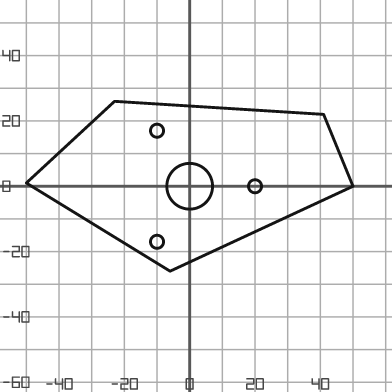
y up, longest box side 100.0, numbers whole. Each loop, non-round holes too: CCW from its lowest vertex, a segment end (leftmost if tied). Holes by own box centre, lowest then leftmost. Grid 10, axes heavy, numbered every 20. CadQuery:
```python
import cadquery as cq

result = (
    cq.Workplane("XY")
    .moveTo(-6.0, -26.0)
    .lineTo(50.0, 0.0)
    .lineTo(41.0, 22.0)
    .lineTo(-23.0, 26.0)
    .lineTo(-50.0, 1.0)
    .close()
    .moveTo(-10.0, -17.0)
    .circle(2.0)
    .moveTo(0.0, 0.0)
    .circle(7.0)
    .moveTo(20.0, 0.0)
    .circle(2.0)
    .moveTo(-10.0, 17.0)
    .circle(2.0)
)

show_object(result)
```